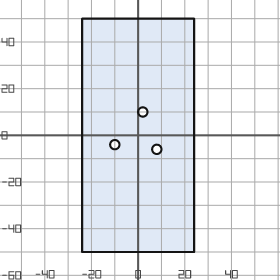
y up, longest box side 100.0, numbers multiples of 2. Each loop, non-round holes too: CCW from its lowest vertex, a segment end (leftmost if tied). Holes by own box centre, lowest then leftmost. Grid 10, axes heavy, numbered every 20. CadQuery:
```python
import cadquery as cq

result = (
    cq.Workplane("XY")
    .moveTo(-24.0, -50.0)
    .lineTo(24.0, -50.0)
    .lineTo(24.0, 50.0)
    .lineTo(-24.0, 50.0)
    .close()
    .moveTo(8.0, -6.0)
    .circle(2.0)
    .moveTo(-10.0, -4.0)
    .circle(2.0)
    .moveTo(2.0, 10.0)
    .circle(2.0)
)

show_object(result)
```